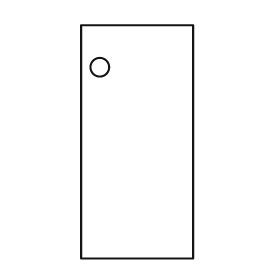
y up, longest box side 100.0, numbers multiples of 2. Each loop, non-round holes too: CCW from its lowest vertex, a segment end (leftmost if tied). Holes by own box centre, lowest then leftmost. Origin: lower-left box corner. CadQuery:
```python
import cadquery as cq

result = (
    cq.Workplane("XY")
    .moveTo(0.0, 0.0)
    .lineTo(48.0, 0.0)
    .lineTo(48.0, 100.0)
    .lineTo(0.0, 100.0)
    .close()
    .moveTo(8.0, 82.0)
    .circle(4.0)
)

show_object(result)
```